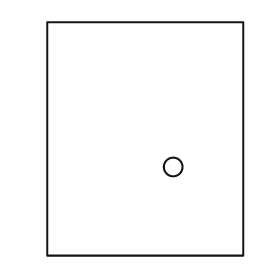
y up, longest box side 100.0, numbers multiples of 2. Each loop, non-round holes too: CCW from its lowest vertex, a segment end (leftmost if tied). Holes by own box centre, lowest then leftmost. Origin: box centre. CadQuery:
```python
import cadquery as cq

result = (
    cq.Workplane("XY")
    .moveTo(-42.0, -50.0)
    .lineTo(42.0, -50.0)
    .lineTo(42.0, 50.0)
    .lineTo(-42.0, 50.0)
    .close()
    .moveTo(12.0, -12.0)
    .circle(4.0)
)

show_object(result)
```